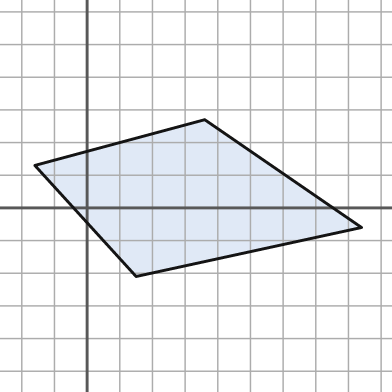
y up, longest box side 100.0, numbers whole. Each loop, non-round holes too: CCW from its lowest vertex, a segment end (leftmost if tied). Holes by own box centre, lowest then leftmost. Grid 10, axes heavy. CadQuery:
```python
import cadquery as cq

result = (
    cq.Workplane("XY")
    .moveTo(15.0, -21.0)
    .lineTo(84.0, -6.0)
    .lineTo(36.0, 27.0)
    .lineTo(-16.0, 13.0)
    .close()
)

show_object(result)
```